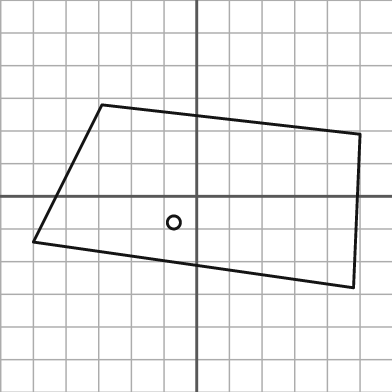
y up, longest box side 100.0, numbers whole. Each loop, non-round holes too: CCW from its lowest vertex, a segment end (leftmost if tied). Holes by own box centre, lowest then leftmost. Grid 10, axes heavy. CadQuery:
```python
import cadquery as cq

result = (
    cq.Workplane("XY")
    .moveTo(48.0, -28.0)
    .lineTo(50.0, 19.0)
    .lineTo(-29.0, 28.0)
    .lineTo(-50.0, -14.0)
    .close()
    .moveTo(-7.0, -8.0)
    .circle(2.0)
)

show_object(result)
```